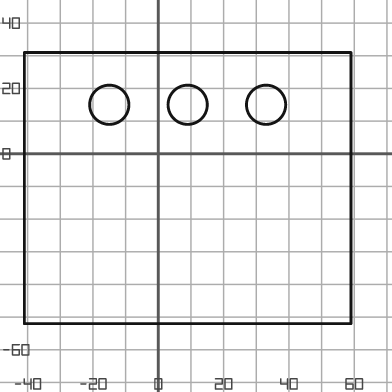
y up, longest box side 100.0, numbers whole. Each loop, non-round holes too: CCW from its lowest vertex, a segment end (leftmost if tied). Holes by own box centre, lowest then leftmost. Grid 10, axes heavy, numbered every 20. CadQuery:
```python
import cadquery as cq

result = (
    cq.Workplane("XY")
    .moveTo(-41.0, -52.0)
    .lineTo(59.0, -52.0)
    .lineTo(59.0, 31.0)
    .lineTo(-41.0, 31.0)
    .close()
    .moveTo(-15.0, 15.0)
    .circle(6.0)
    .moveTo(9.0, 15.0)
    .circle(6.0)
    .moveTo(33.0, 15.0)
    .circle(6.0)
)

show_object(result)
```